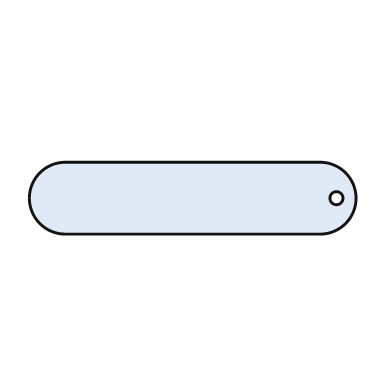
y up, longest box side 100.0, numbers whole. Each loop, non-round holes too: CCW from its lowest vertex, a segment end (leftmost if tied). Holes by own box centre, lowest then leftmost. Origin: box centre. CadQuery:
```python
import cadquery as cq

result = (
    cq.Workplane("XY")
    .moveTo(-39.0, -11.0)
    .lineTo(39.0, -11.0)
    .threePointArc((50.0, 0.0), (39.0, 11.0))
    .lineTo(-39.0, 11.0)
    .threePointArc((-50.0, 0.0), (-39.0, -11.0))
    .close()
    .moveTo(44.0, 0.0)
    .circle(2.0)
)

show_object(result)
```